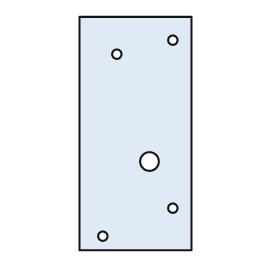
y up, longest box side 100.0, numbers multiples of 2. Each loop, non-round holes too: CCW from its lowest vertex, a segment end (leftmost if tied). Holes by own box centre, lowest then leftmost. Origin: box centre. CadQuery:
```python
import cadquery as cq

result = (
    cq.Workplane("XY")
    .moveTo(-24.0, -50.0)
    .lineTo(24.0, -50.0)
    .lineTo(24.0, 50.0)
    .lineTo(-24.0, 50.0)
    .close()
    .moveTo(-14.0, -44.0)
    .circle(2.0)
    .moveTo(16.0, -32.0)
    .circle(2.0)
    .moveTo(6.0, -12.0)
    .circle(4.0)
    .moveTo(-8.0, 34.0)
    .circle(2.0)
    .moveTo(16.0, 40.0)
    .circle(2.0)
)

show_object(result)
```